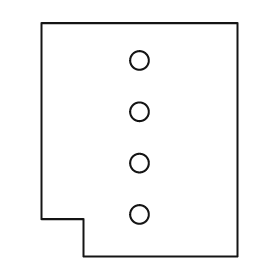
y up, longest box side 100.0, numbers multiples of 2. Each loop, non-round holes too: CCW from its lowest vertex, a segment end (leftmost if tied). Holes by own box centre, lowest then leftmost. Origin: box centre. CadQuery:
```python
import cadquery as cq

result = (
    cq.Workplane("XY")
    .moveTo(-24.0, -50.0)
    .lineTo(42.0, -50.0)
    .lineTo(42.0, 50.0)
    .lineTo(-42.0, 50.0)
    .lineTo(-42.0, -34.0)
    .lineTo(-24.0, -34.0)
    .close()
    .moveTo(0.0, -32.0)
    .circle(4.0)
    .moveTo(0.0, -10.0)
    .circle(4.0)
    .moveTo(0.0, 12.0)
    .circle(4.0)
    .moveTo(0.0, 34.0)
    .circle(4.0)
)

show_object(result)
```